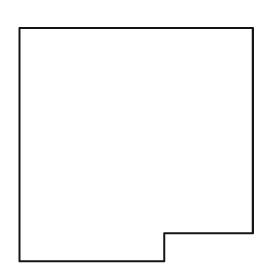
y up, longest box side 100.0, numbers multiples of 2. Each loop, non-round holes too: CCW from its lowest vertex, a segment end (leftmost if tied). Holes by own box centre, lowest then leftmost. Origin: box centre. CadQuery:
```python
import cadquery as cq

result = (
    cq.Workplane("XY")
    .moveTo(-50.0, -50.0)
    .lineTo(12.0, -50.0)
    .lineTo(12.0, -38.0)
    .lineTo(50.0, -38.0)
    .lineTo(50.0, 50.0)
    .lineTo(-50.0, 50.0)
    .close()
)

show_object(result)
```